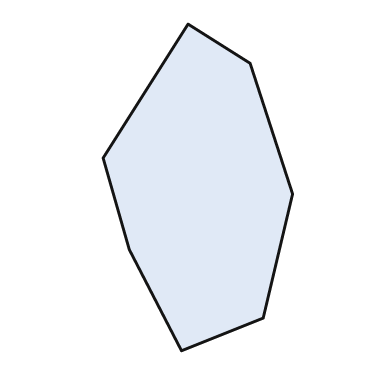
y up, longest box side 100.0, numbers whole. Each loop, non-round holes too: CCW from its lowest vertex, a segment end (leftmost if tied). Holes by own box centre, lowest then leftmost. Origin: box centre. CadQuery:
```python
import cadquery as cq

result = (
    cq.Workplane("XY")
    .moveTo(-5.0, -50.0)
    .lineTo(20.0, -40.0)
    .lineTo(29.0, -2.0)
    .lineTo(16.0, 38.0)
    .lineTo(-3.0, 50.0)
    .lineTo(-29.0, 9.0)
    .lineTo(-21.0, -19.0)
    .close()
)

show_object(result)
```